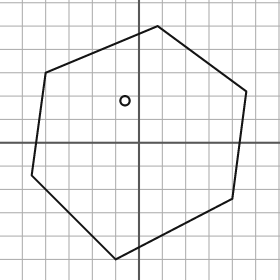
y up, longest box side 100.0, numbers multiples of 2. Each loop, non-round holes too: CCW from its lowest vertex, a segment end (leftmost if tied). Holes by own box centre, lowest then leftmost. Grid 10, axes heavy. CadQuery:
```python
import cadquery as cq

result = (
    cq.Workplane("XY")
    .moveTo(-10.0, -50.0)
    .lineTo(40.0, -24.0)
    .lineTo(46.0, 22.0)
    .lineTo(8.0, 50.0)
    .lineTo(-40.0, 30.0)
    .lineTo(-46.0, -14.0)
    .close()
    .moveTo(-6.0, 18.0)
    .circle(2.0)
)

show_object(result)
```